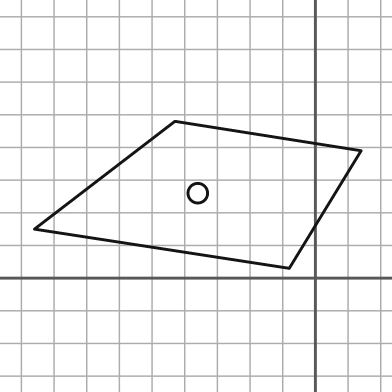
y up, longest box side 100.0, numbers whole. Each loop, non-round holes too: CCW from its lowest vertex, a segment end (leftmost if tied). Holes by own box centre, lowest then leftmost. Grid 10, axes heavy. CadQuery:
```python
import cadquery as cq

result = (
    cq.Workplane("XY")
    .moveTo(-8.0, 3.0)
    .lineTo(14.0, 39.0)
    .lineTo(-43.0, 48.0)
    .lineTo(-86.0, 15.0)
    .close()
    .moveTo(-36.0, 26.0)
    .circle(3.0)
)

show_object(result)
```